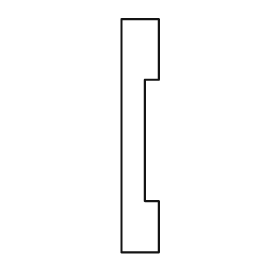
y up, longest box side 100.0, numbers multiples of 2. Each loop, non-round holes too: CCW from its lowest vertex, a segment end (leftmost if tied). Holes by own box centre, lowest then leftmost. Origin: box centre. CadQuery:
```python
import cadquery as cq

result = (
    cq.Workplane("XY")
    .moveTo(-8.0, -50.0)
    .lineTo(8.0, -50.0)
    .lineTo(8.0, -28.0)
    .lineTo(2.0, -28.0)
    .lineTo(2.0, 24.0)
    .lineTo(8.0, 24.0)
    .lineTo(8.0, 50.0)
    .lineTo(-8.0, 50.0)
    .close()
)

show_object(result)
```